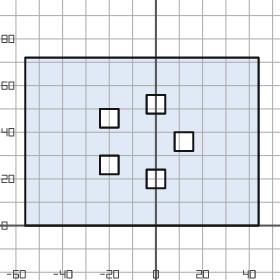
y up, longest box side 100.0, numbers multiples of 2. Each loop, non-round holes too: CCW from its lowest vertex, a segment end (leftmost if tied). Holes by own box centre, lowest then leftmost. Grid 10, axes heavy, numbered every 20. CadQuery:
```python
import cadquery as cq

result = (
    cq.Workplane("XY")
    .moveTo(-56.0, 0.0)
    .lineTo(44.0, 0.0)
    .lineTo(44.0, 72.0)
    .lineTo(-56.0, 72.0)
    .close()
    .moveTo(-4.0, 16.0)
    .lineTo(4.0, 16.0)
    .lineTo(4.0, 24.0)
    .lineTo(-4.0, 24.0)
    .close()
    .moveTo(-24.0, 22.0)
    .lineTo(-16.0, 22.0)
    .lineTo(-16.0, 30.0)
    .lineTo(-24.0, 30.0)
    .close()
    .moveTo(8.0, 32.0)
    .lineTo(16.0, 32.0)
    .lineTo(16.0, 40.0)
    .lineTo(8.0, 40.0)
    .close()
    .moveTo(-24.0, 42.0)
    .lineTo(-16.0, 42.0)
    .lineTo(-16.0, 50.0)
    .lineTo(-24.0, 50.0)
    .close()
    .moveTo(-4.0, 48.0)
    .lineTo(4.0, 48.0)
    .lineTo(4.0, 56.0)
    .lineTo(-4.0, 56.0)
    .close()
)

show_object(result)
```